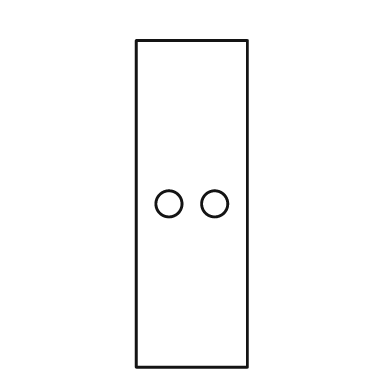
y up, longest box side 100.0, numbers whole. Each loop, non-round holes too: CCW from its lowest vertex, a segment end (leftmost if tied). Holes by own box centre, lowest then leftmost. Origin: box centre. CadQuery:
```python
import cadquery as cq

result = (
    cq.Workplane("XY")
    .moveTo(-17.0, -50.0)
    .lineTo(17.0, -50.0)
    .lineTo(17.0, 50.0)
    .lineTo(-17.0, 50.0)
    .close()
    .moveTo(-7.0, 0.0)
    .circle(4.0)
    .moveTo(7.0, 0.0)
    .circle(4.0)
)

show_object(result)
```